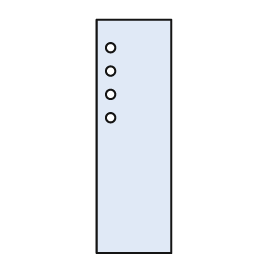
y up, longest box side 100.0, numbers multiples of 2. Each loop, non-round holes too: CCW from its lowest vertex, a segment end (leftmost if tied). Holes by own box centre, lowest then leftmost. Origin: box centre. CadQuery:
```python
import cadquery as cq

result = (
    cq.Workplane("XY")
    .moveTo(-16.0, -50.0)
    .lineTo(16.0, -50.0)
    .lineTo(16.0, 50.0)
    .lineTo(-16.0, 50.0)
    .close()
    .moveTo(-10.0, 8.0)
    .circle(2.0)
    .moveTo(-10.0, 18.0)
    .circle(2.0)
    .moveTo(-10.0, 28.0)
    .circle(2.0)
    .moveTo(-10.0, 38.0)
    .circle(2.0)
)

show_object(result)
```